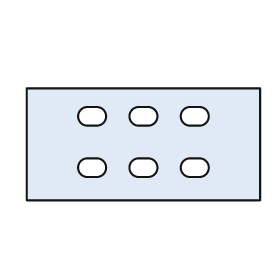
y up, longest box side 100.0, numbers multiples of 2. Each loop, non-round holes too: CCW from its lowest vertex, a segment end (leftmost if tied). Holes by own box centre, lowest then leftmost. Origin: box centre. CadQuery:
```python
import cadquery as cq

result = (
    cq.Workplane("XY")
    .moveTo(-50.0, -24.0)
    .lineTo(50.0, -24.0)
    .lineTo(50.0, 24.0)
    .lineTo(-50.0, 24.0)
    .close()
    .moveTo(-24.0, -14.0)
    .lineTo(-20.0, -14.0)
    .threePointArc((-16.0, -10.0), (-20.0, -6.0))
    .lineTo(-24.0, -6.0)
    .threePointArc((-28.0, -10.0), (-24.0, -14.0))
    .close()
    .moveTo(-2.0, -14.0)
    .lineTo(2.0, -14.0)
    .threePointArc((6.0, -10.0), (2.0, -6.0))
    .lineTo(-2.0, -6.0)
    .threePointArc((-6.0, -10.0), (-2.0, -14.0))
    .close()
    .moveTo(20.0, -14.0)
    .lineTo(24.0, -14.0)
    .threePointArc((28.0, -10.0), (24.0, -6.0))
    .lineTo(20.0, -6.0)
    .threePointArc((16.0, -10.0), (20.0, -14.0))
    .close()
    .moveTo(-24.0, 8.0)
    .lineTo(-20.0, 8.0)
    .threePointArc((-16.0, 12.0), (-20.0, 16.0))
    .lineTo(-24.0, 16.0)
    .threePointArc((-28.0, 12.0), (-24.0, 8.0))
    .close()
    .moveTo(-2.0, 8.0)
    .lineTo(2.0, 8.0)
    .threePointArc((6.0, 12.0), (2.0, 16.0))
    .lineTo(-2.0, 16.0)
    .threePointArc((-6.0, 12.0), (-2.0, 8.0))
    .close()
    .moveTo(20.0, 8.0)
    .lineTo(24.0, 8.0)
    .threePointArc((28.0, 12.0), (24.0, 16.0))
    .lineTo(20.0, 16.0)
    .threePointArc((16.0, 12.0), (20.0, 8.0))
    .close()
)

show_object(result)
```